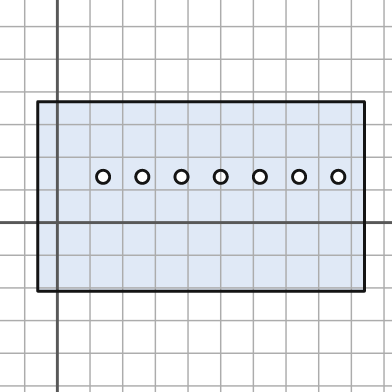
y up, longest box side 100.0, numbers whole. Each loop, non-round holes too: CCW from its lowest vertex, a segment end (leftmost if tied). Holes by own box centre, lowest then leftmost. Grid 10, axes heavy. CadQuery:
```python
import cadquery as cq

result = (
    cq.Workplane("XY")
    .moveTo(-6.0, -21.0)
    .lineTo(94.0, -21.0)
    .lineTo(94.0, 37.0)
    .lineTo(-6.0, 37.0)
    .close()
    .moveTo(14.0, 14.0)
    .circle(2.0)
    .moveTo(26.0, 14.0)
    .circle(2.0)
    .moveTo(38.0, 14.0)
    .circle(2.0)
    .moveTo(50.0, 14.0)
    .circle(2.0)
    .moveTo(62.0, 14.0)
    .circle(2.0)
    .moveTo(74.0, 14.0)
    .circle(2.0)
    .moveTo(86.0, 14.0)
    .circle(2.0)
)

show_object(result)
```